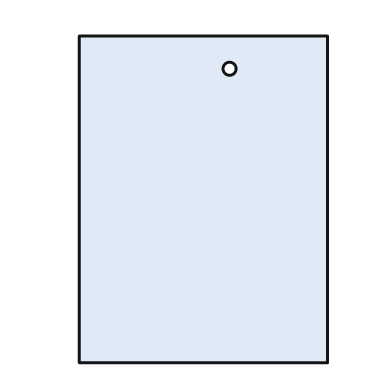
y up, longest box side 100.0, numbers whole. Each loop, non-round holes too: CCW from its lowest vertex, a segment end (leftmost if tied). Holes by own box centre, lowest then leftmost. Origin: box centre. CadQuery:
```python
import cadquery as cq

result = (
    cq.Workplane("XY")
    .moveTo(-38.0, -50.0)
    .lineTo(38.0, -50.0)
    .lineTo(38.0, 50.0)
    .lineTo(-38.0, 50.0)
    .close()
    .moveTo(8.0, 40.0)
    .circle(2.0)
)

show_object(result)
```